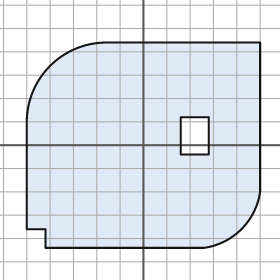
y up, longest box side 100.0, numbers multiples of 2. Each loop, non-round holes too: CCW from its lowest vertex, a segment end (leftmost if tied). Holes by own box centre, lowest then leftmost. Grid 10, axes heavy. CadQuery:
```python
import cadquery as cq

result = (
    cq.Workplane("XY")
    .moveTo(-42.0, -44.0)
    .lineTo(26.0, -44.0)
    .threePointArc((42.0, -36.0), (50.0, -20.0))
    .lineTo(50.0, 44.0)
    .lineTo(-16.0, 44.0)
    .threePointArc((-40.0, 34.0), (-50.0, 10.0))
    .lineTo(-50.0, -36.0)
    .lineTo(-42.0, -36.0)
    .close()
    .moveTo(16.0, -4.0)
    .lineTo(28.0, -4.0)
    .lineTo(28.0, 12.0)
    .lineTo(16.0, 12.0)
    .close()
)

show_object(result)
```